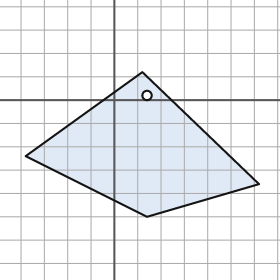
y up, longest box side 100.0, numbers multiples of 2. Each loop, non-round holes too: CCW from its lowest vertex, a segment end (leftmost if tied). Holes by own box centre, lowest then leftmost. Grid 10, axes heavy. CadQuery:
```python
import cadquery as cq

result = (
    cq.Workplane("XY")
    .moveTo(14.0, -50.0)
    .lineTo(62.0, -36.0)
    .lineTo(12.0, 12.0)
    .lineTo(-38.0, -24.0)
    .close()
    .moveTo(14.0, 2.0)
    .circle(2.0)
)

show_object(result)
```